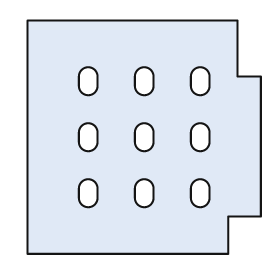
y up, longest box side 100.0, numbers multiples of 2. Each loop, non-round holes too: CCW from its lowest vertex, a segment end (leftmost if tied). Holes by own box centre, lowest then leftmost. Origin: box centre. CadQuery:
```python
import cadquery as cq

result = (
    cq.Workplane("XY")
    .moveTo(-50.0, -50.0)
    .lineTo(36.0, -50.0)
    .lineTo(36.0, -34.0)
    .lineTo(50.0, -34.0)
    .lineTo(50.0, 26.0)
    .lineTo(40.0, 26.0)
    .lineTo(40.0, 50.0)
    .lineTo(-50.0, 50.0)
    .close()
    .moveTo(-28.0, -26.0)
    .threePointArc((-24.0, -30.0), (-20.0, -26.0))
    .lineTo(-20.0, -22.0)
    .threePointArc((-24.0, -18.0), (-28.0, -22.0))
    .close()
    .moveTo(-4.0, -26.0)
    .threePointArc((0.0, -30.0), (4.0, -26.0))
    .lineTo(4.0, -22.0)
    .threePointArc((0.0, -18.0), (-4.0, -22.0))
    .close()
    .moveTo(20.0, -26.0)
    .threePointArc((24.0, -30.0), (28.0, -26.0))
    .lineTo(28.0, -22.0)
    .threePointArc((24.0, -18.0), (20.0, -22.0))
    .close()
    .moveTo(-28.0, -2.0)
    .threePointArc((-24.0, -6.0), (-20.0, -2.0))
    .lineTo(-20.0, 2.0)
    .threePointArc((-24.0, 6.0), (-28.0, 2.0))
    .close()
    .moveTo(-4.0, -2.0)
    .threePointArc((0.0, -6.0), (4.0, -2.0))
    .lineTo(4.0, 2.0)
    .threePointArc((0.0, 6.0), (-4.0, 2.0))
    .close()
    .moveTo(20.0, -2.0)
    .threePointArc((24.0, -6.0), (28.0, -2.0))
    .lineTo(28.0, 2.0)
    .threePointArc((24.0, 6.0), (20.0, 2.0))
    .close()
    .moveTo(-28.0, 22.0)
    .threePointArc((-24.0, 18.0), (-20.0, 22.0))
    .lineTo(-20.0, 26.0)
    .threePointArc((-24.0, 30.0), (-28.0, 26.0))
    .close()
    .moveTo(-4.0, 22.0)
    .threePointArc((0.0, 18.0), (4.0, 22.0))
    .lineTo(4.0, 26.0)
    .threePointArc((0.0, 30.0), (-4.0, 26.0))
    .close()
    .moveTo(20.0, 22.0)
    .threePointArc((24.0, 18.0), (28.0, 22.0))
    .lineTo(28.0, 26.0)
    .threePointArc((24.0, 30.0), (20.0, 26.0))
    .close()
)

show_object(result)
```